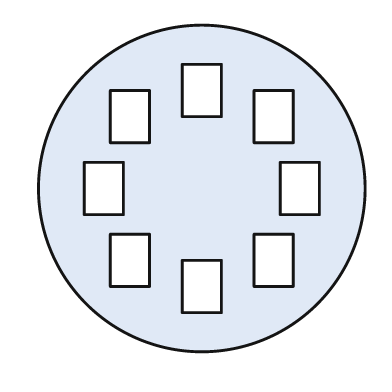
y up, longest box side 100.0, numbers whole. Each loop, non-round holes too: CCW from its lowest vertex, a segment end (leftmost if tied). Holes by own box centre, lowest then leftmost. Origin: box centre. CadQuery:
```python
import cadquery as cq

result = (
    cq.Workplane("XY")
    .moveTo(0.0, 0.0)
    .circle(50.0)
    .moveTo(-6.0, -38.0)
    .lineTo(6.0, -38.0)
    .lineTo(6.0, -22.0)
    .lineTo(-6.0, -22.0)
    .close()
    .moveTo(-28.0, -30.0)
    .lineTo(-16.0, -30.0)
    .lineTo(-16.0, -14.0)
    .lineTo(-28.0, -14.0)
    .close()
    .moveTo(16.0, -30.0)
    .lineTo(28.0, -30.0)
    .lineTo(28.0, -14.0)
    .lineTo(16.0, -14.0)
    .close()
    .moveTo(-36.0, -8.0)
    .lineTo(-24.0, -8.0)
    .lineTo(-24.0, 8.0)
    .lineTo(-36.0, 8.0)
    .close()
    .moveTo(24.0, -8.0)
    .lineTo(36.0, -8.0)
    .lineTo(36.0, 8.0)
    .lineTo(24.0, 8.0)
    .close()
    .moveTo(-28.0, 14.0)
    .lineTo(-16.0, 14.0)
    .lineTo(-16.0, 30.0)
    .lineTo(-28.0, 30.0)
    .close()
    .moveTo(16.0, 14.0)
    .lineTo(28.0, 14.0)
    .lineTo(28.0, 30.0)
    .lineTo(16.0, 30.0)
    .close()
    .moveTo(-6.0, 22.0)
    .lineTo(6.0, 22.0)
    .lineTo(6.0, 38.0)
    .lineTo(-6.0, 38.0)
    .close()
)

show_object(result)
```